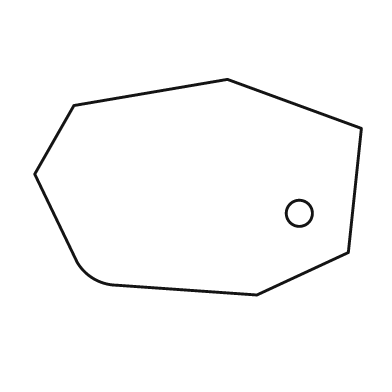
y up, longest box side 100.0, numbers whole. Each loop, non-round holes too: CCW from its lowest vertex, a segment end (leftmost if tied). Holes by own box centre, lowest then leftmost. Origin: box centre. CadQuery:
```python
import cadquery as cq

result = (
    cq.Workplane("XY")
    .moveTo(18.0, -33.0)
    .lineTo(46.0, -20.0)
    .lineTo(50.0, 18.0)
    .lineTo(9.0, 33.0)
    .lineTo(-38.0, 25.0)
    .lineTo(-50.0, 4.0)
    .lineTo(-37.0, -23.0)
    .threePointArc((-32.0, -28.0), (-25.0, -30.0))
    .close()
    .moveTo(31.0, -8.0)
    .circle(4.0)
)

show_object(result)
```